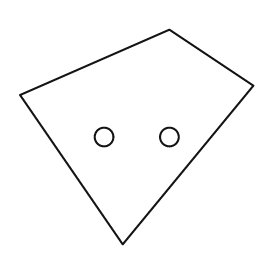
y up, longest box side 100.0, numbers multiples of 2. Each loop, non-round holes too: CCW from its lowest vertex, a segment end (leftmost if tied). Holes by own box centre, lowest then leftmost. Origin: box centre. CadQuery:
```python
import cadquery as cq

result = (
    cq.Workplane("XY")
    .moveTo(-6.0, -46.0)
    .lineTo(50.0, 22.0)
    .lineTo(14.0, 46.0)
    .lineTo(-50.0, 18.0)
    .close()
    .moveTo(-14.0, 0.0)
    .circle(4.0)
    .moveTo(14.0, 0.0)
    .circle(4.0)
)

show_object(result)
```